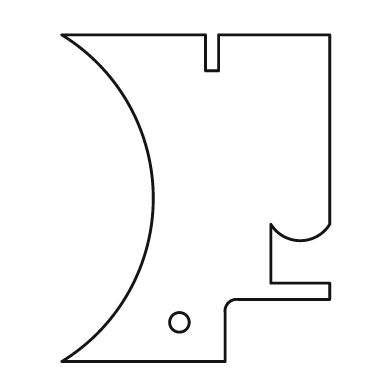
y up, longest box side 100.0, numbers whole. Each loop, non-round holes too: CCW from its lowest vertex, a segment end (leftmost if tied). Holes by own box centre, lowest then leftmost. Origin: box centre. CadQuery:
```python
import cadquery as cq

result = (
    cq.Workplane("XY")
    .moveTo(-41.0, -50.0)
    .lineTo(9.0, -50.0)
    .lineTo(9.0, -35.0)
    .threePointArc((10.0, -32.0), (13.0, -31.0))
    .lineTo(41.0, -31.0)
    .lineTo(41.0, -26.0)
    .lineTo(23.0, -26.0)
    .lineTo(23.0, -8.0)
    .threePointArc((32.0, -13.0), (41.0, -8.0))
    .lineTo(41.0, 50.0)
    .lineTo(7.0, 50.0)
    .lineTo(7.0, 39.0)
    .lineTo(3.0, 39.0)
    .lineTo(3.0, 50.0)
    .lineTo(-41.0, 50.0)
    .threePointArc((-13.0, 0.0), (-41.0, -50.0))
    .close()
    .moveTo(-5.0, -38.0)
    .circle(3.0)
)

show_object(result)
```